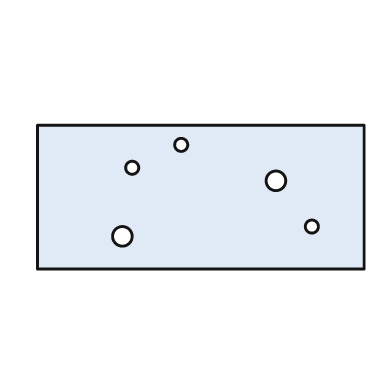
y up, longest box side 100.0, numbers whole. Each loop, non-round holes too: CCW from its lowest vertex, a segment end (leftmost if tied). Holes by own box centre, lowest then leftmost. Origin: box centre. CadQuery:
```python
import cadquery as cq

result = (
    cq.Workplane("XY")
    .moveTo(-50.0, -22.0)
    .lineTo(50.0, -22.0)
    .lineTo(50.0, 22.0)
    .lineTo(-50.0, 22.0)
    .close()
    .moveTo(-24.0, -12.0)
    .circle(3.0)
    .moveTo(34.0, -9.0)
    .circle(2.0)
    .moveTo(23.0, 5.0)
    .circle(3.0)
    .moveTo(-21.0, 9.0)
    .circle(2.0)
    .moveTo(-6.0, 16.0)
    .circle(2.0)
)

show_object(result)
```